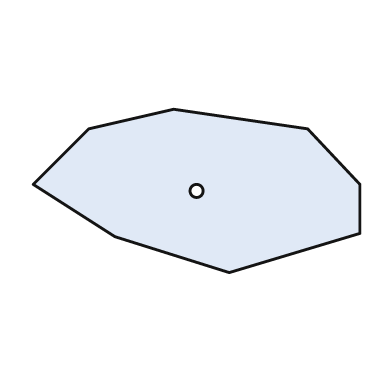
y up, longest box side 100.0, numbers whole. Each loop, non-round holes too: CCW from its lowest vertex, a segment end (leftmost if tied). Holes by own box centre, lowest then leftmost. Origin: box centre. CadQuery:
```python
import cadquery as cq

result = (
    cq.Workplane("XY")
    .moveTo(10.0, -25.0)
    .lineTo(50.0, -13.0)
    .lineTo(50.0, 2.0)
    .lineTo(34.0, 19.0)
    .lineTo(-7.0, 25.0)
    .lineTo(-33.0, 19.0)
    .lineTo(-50.0, 2.0)
    .lineTo(-25.0, -14.0)
    .close()
    .moveTo(0.0, 0.0)
    .circle(2.0)
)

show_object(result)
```